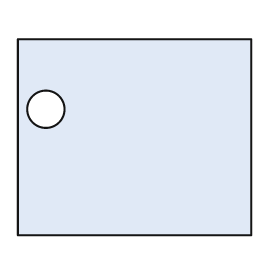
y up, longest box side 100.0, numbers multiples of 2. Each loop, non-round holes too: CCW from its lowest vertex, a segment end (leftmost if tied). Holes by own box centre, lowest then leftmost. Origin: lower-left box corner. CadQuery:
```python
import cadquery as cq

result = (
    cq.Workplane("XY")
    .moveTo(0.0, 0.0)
    .lineTo(100.0, 0.0)
    .lineTo(100.0, 84.0)
    .lineTo(0.0, 84.0)
    .close()
    .moveTo(12.0, 54.0)
    .circle(8.0)
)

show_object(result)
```